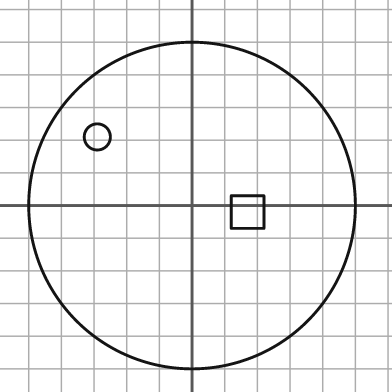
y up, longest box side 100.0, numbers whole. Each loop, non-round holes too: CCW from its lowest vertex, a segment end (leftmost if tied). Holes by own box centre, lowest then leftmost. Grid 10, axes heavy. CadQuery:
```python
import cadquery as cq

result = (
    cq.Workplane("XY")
    .moveTo(0.0, 0.0)
    .circle(50.0)
    .moveTo(12.0, -7.0)
    .lineTo(22.0, -7.0)
    .lineTo(22.0, 3.0)
    .lineTo(12.0, 3.0)
    .close()
    .moveTo(-29.0, 21.0)
    .circle(4.0)
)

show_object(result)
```